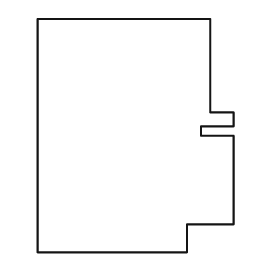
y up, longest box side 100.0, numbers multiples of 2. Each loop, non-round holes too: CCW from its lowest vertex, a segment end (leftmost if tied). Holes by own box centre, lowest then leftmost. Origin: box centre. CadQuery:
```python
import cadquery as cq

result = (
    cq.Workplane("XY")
    .moveTo(-42.0, -50.0)
    .lineTo(22.0, -50.0)
    .lineTo(22.0, -38.0)
    .lineTo(42.0, -38.0)
    .lineTo(42.0, 0.0)
    .lineTo(28.0, 0.0)
    .lineTo(28.0, 4.0)
    .lineTo(42.0, 4.0)
    .lineTo(42.0, 10.0)
    .lineTo(32.0, 10.0)
    .lineTo(32.0, 50.0)
    .lineTo(-42.0, 50.0)
    .close()
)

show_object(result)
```